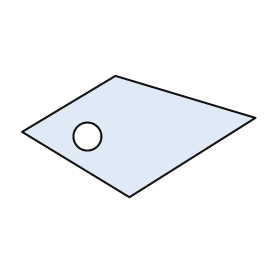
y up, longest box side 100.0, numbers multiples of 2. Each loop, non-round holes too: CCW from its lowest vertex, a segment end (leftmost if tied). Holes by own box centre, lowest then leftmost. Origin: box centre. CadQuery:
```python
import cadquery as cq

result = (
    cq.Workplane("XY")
    .moveTo(-4.0, -26.0)
    .lineTo(50.0, 8.0)
    .lineTo(-10.0, 26.0)
    .lineTo(-50.0, 2.0)
    .close()
    .moveTo(-22.0, 0.0)
    .circle(6.0)
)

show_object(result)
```